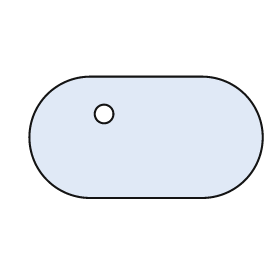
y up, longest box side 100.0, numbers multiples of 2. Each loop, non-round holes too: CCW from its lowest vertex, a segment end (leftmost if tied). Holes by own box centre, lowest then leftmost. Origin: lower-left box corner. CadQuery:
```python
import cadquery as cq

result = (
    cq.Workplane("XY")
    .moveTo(26.0, 0.0)
    .lineTo(74.0, 0.0)
    .threePointArc((100.0, 26.0), (74.0, 52.0))
    .lineTo(26.0, 52.0)
    .threePointArc((0.0, 26.0), (26.0, 0.0))
    .close()
    .moveTo(32.0, 36.0)
    .circle(4.0)
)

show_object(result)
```